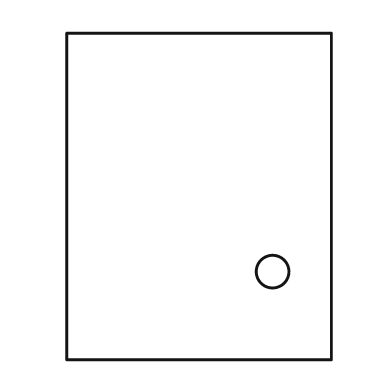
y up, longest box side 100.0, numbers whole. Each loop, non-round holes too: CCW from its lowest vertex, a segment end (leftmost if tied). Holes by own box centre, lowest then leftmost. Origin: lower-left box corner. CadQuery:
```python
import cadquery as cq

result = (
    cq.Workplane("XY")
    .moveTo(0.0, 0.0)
    .lineTo(81.0, 0.0)
    .lineTo(81.0, 100.0)
    .lineTo(0.0, 100.0)
    .close()
    .moveTo(63.0, 27.0)
    .circle(5.0)
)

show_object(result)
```